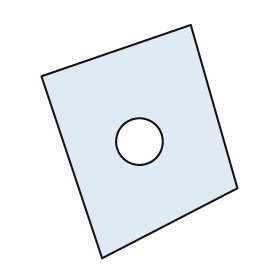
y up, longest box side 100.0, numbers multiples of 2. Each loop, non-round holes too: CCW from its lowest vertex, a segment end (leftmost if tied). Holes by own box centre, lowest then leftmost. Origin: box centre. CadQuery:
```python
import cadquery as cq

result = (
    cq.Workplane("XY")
    .moveTo(-16.0, -50.0)
    .lineTo(42.0, -20.0)
    .lineTo(22.0, 50.0)
    .lineTo(-42.0, 28.0)
    .close()
    .moveTo(0.0, 0.0)
    .circle(10.0)
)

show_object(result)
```